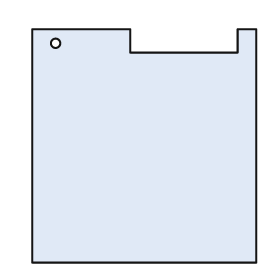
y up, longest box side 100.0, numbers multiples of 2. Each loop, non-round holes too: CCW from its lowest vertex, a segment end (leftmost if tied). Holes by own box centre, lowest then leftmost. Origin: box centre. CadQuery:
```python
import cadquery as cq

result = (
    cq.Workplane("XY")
    .moveTo(-48.0, -50.0)
    .lineTo(48.0, -50.0)
    .lineTo(48.0, 50.0)
    .lineTo(40.0, 50.0)
    .lineTo(40.0, 40.0)
    .lineTo(-6.0, 40.0)
    .lineTo(-6.0, 50.0)
    .lineTo(-48.0, 50.0)
    .close()
    .moveTo(-38.0, 44.0)
    .circle(2.0)
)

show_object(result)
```